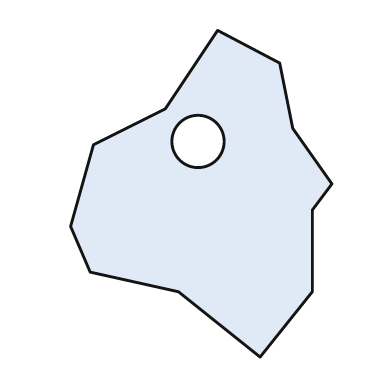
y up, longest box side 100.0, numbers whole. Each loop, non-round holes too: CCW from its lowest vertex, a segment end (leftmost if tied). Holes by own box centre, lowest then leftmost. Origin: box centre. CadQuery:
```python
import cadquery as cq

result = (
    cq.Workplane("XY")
    .moveTo(18.0, -50.0)
    .lineTo(34.0, -30.0)
    .lineTo(34.0, -5.0)
    .lineTo(40.0, 3.0)
    .lineTo(28.0, 20.0)
    .lineTo(24.0, 40.0)
    .lineTo(5.0, 50.0)
    .lineTo(-11.0, 26.0)
    .lineTo(-33.0, 15.0)
    .lineTo(-40.0, -10.0)
    .lineTo(-34.0, -24.0)
    .lineTo(-7.0, -30.0)
    .close()
    .moveTo(-1.0, 16.0)
    .circle(8.0)
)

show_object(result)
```